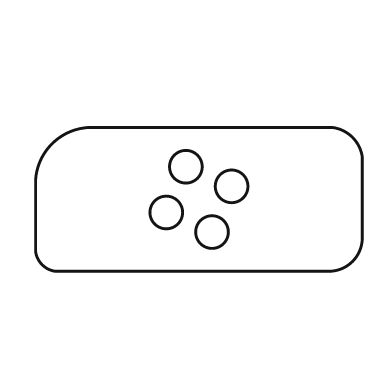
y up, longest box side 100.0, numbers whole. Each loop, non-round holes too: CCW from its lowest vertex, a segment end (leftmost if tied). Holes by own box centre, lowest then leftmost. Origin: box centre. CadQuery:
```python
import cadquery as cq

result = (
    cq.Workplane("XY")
    .moveTo(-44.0, -22.0)
    .lineTo(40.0, -22.0)
    .threePointArc((47.0, -19.0), (50.0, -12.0))
    .lineTo(50.0, 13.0)
    .threePointArc((47.0, 19.0), (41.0, 22.0))
    .lineTo(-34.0, 22.0)
    .threePointArc((-45.0, 17.0), (-50.0, 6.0))
    .lineTo(-50.0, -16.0)
    .threePointArc((-48.0, -20.0), (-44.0, -22.0))
    .close()
    .moveTo(4.0, -10.0)
    .circle(5.0)
    .moveTo(-10.0, -4.0)
    .circle(5.0)
    .moveTo(10.0, 4.0)
    .circle(5.0)
    .moveTo(-4.0, 10.0)
    .circle(5.0)
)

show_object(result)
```